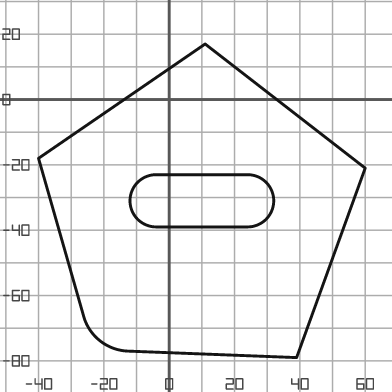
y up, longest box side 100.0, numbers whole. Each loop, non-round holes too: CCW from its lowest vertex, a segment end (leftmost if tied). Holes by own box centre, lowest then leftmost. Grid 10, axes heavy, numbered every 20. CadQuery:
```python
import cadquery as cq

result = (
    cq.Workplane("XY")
    .moveTo(39.0, -79.0)
    .lineTo(60.0, -21.0)
    .lineTo(11.0, 17.0)
    .lineTo(-40.0, -18.0)
    .lineTo(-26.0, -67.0)
    .threePointArc((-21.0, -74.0), (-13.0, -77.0))
    .close()
    .moveTo(-4.0, -39.0)
    .lineTo(24.0, -39.0)
    .threePointArc((32.0, -31.0), (24.0, -23.0))
    .lineTo(-4.0, -23.0)
    .threePointArc((-12.0, -31.0), (-4.0, -39.0))
    .close()
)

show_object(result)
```